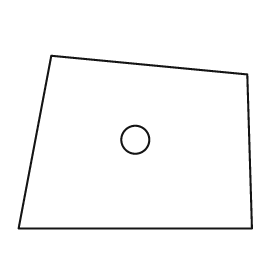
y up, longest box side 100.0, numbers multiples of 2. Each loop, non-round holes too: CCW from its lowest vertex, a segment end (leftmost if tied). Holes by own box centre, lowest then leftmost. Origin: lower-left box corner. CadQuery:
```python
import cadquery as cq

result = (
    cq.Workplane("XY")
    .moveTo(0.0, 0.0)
    .lineTo(100.0, 0.0)
    .lineTo(98.0, 66.0)
    .lineTo(14.0, 74.0)
    .close()
    .moveTo(50.0, 38.0)
    .circle(6.0)
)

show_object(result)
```